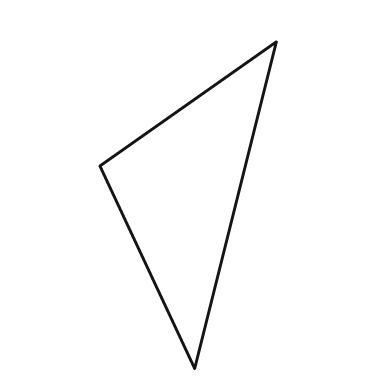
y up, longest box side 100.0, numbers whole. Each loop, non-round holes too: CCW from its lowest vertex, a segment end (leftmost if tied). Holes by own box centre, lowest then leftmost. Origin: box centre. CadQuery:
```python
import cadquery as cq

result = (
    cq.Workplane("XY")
    .moveTo(2.0, -50.0)
    .lineTo(27.0, 50.0)
    .lineTo(-27.0, 12.0)
    .close()
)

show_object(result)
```